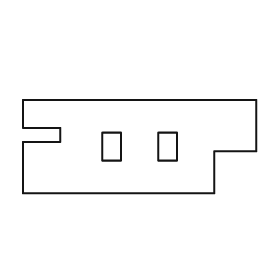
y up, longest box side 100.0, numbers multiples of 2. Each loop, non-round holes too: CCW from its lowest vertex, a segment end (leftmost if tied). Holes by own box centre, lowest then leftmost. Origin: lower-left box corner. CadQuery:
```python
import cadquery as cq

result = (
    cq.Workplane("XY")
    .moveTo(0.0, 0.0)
    .lineTo(82.0, 0.0)
    .lineTo(82.0, 18.0)
    .lineTo(100.0, 18.0)
    .lineTo(100.0, 40.0)
    .lineTo(0.0, 40.0)
    .lineTo(0.0, 28.0)
    .lineTo(16.0, 28.0)
    .lineTo(16.0, 22.0)
    .lineTo(0.0, 22.0)
    .close()
    .moveTo(34.0, 14.0)
    .lineTo(42.0, 14.0)
    .lineTo(42.0, 26.0)
    .lineTo(34.0, 26.0)
    .close()
    .moveTo(58.0, 14.0)
    .lineTo(66.0, 14.0)
    .lineTo(66.0, 26.0)
    .lineTo(58.0, 26.0)
    .close()
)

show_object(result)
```